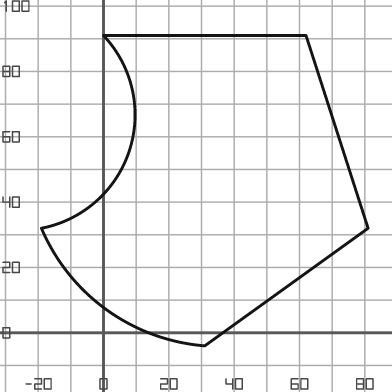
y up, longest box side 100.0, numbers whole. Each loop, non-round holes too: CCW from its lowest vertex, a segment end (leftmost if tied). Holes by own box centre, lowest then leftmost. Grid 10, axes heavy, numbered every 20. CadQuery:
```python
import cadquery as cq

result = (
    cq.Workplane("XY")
    .moveTo(31.0, -4.0)
    .lineTo(81.0, 32.0)
    .lineTo(62.0, 91.0)
    .lineTo(0.0, 91.0)
    .threePointArc((8.0, 56.0), (-19.0, 32.0))
    .threePointArc((1.0, 7.0), (31.0, -4.0))
    .close()
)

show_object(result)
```